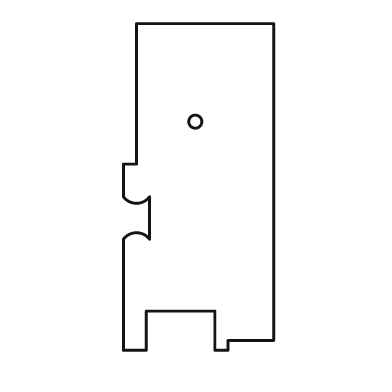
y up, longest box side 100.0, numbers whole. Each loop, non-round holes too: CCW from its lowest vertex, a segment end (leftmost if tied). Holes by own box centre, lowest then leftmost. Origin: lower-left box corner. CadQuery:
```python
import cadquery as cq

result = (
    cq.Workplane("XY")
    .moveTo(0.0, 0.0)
    .lineTo(7.0, 0.0)
    .lineTo(7.0, 12.0)
    .lineTo(28.0, 12.0)
    .lineTo(28.0, 0.0)
    .lineTo(32.0, 0.0)
    .lineTo(32.0, 3.0)
    .lineTo(46.0, 3.0)
    .lineTo(46.0, 100.0)
    .lineTo(4.0, 100.0)
    .lineTo(4.0, 57.0)
    .lineTo(0.0, 57.0)
    .lineTo(0.0, 47.0)
    .threePointArc((4.0, 45.0), (8.0, 47.0))
    .lineTo(8.0, 34.0)
    .threePointArc((4.0, 36.0), (0.0, 34.0))
    .close()
    .moveTo(22.0, 70.0)
    .circle(2.0)
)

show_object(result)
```